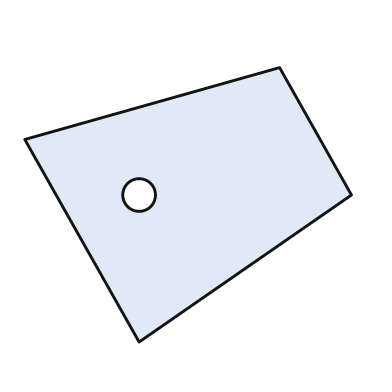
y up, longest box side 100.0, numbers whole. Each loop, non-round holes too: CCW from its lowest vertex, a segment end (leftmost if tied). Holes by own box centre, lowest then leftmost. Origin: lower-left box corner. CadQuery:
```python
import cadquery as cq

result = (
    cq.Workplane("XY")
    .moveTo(35.0, 0.0)
    .lineTo(100.0, 45.0)
    .lineTo(78.0, 84.0)
    .lineTo(0.0, 62.0)
    .close()
    .moveTo(35.0, 45.0)
    .circle(5.0)
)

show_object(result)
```